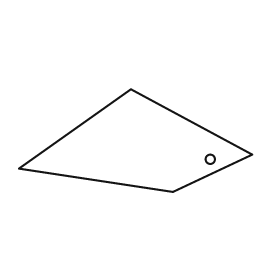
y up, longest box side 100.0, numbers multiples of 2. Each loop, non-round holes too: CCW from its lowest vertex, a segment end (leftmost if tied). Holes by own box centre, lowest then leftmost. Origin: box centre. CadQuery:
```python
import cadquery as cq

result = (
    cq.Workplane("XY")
    .moveTo(16.0, -22.0)
    .lineTo(50.0, -6.0)
    .lineTo(-2.0, 22.0)
    .lineTo(-50.0, -12.0)
    .close()
    .moveTo(32.0, -8.0)
    .circle(2.0)
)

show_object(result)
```